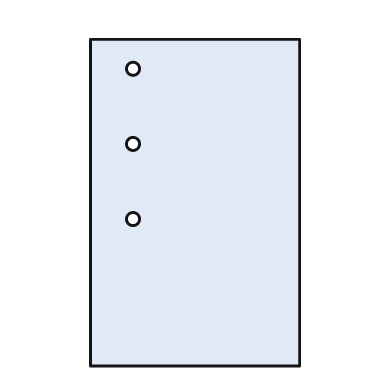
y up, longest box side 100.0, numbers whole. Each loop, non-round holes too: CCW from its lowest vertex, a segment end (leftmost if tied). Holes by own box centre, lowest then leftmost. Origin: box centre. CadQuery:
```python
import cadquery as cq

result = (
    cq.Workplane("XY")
    .moveTo(-32.0, -50.0)
    .lineTo(32.0, -50.0)
    .lineTo(32.0, 50.0)
    .lineTo(-32.0, 50.0)
    .close()
    .moveTo(-19.0, -5.0)
    .circle(2.0)
    .moveTo(-19.0, 18.0)
    .circle(2.0)
    .moveTo(-19.0, 41.0)
    .circle(2.0)
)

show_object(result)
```